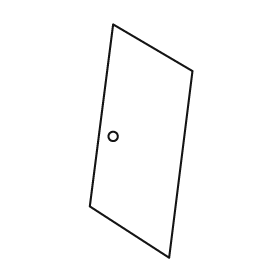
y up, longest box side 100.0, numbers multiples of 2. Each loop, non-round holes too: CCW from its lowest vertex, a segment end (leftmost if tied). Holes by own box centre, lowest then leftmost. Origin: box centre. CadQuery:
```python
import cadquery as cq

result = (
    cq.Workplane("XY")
    .moveTo(12.0, -50.0)
    .lineTo(22.0, 30.0)
    .lineTo(-12.0, 50.0)
    .lineTo(-22.0, -28.0)
    .close()
    .moveTo(-12.0, 2.0)
    .circle(2.0)
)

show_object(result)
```